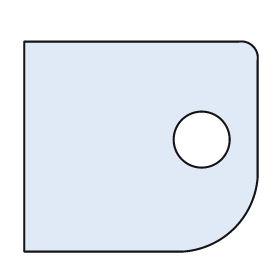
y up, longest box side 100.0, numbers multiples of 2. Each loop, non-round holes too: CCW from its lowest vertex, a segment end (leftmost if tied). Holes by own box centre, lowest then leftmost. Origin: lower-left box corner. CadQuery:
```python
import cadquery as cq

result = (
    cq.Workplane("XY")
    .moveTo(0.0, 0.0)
    .lineTo(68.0, 0.0)
    .threePointArc((90.0, 10.0), (100.0, 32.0))
    .lineTo(100.0, 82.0)
    .threePointArc((98.0, 88.0), (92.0, 90.0))
    .lineTo(0.0, 90.0)
    .close()
    .moveTo(76.0, 48.0)
    .circle(12.0)
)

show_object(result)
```